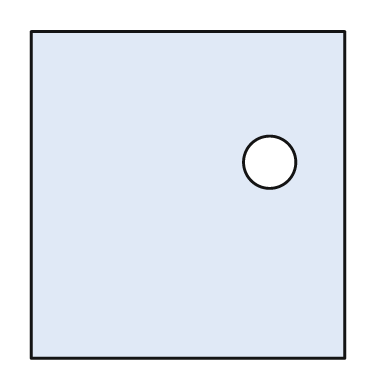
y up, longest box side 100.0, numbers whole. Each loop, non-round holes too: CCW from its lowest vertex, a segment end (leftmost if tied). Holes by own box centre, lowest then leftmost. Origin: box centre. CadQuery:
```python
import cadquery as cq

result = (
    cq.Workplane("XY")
    .moveTo(-48.0, -50.0)
    .lineTo(48.0, -50.0)
    .lineTo(48.0, 50.0)
    .lineTo(-48.0, 50.0)
    .close()
    .moveTo(25.0, 10.0)
    .circle(8.0)
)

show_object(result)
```